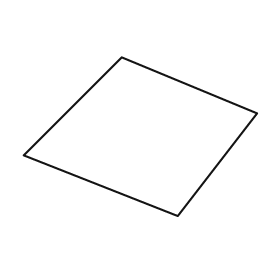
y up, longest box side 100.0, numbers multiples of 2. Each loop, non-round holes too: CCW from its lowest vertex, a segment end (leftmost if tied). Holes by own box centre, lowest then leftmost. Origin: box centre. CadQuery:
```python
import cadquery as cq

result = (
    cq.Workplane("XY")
    .moveTo(16.0, -34.0)
    .lineTo(50.0, 10.0)
    .lineTo(-8.0, 34.0)
    .lineTo(-50.0, -8.0)
    .close()
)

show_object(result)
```